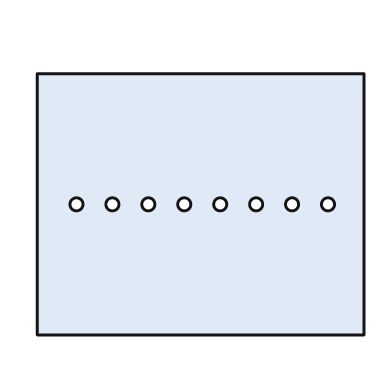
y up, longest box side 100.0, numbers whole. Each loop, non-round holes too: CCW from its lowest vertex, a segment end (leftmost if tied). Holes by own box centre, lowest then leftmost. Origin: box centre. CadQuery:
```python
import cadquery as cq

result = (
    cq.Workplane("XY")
    .moveTo(-50.0, -40.0)
    .lineTo(50.0, -40.0)
    .lineTo(50.0, 40.0)
    .lineTo(-50.0, 40.0)
    .close()
    .moveTo(-38.0, 0.0)
    .circle(2.0)
    .moveTo(-27.0, 0.0)
    .circle(2.0)
    .moveTo(-16.0, 0.0)
    .circle(2.0)
    .moveTo(-5.0, 0.0)
    .circle(2.0)
    .moveTo(6.0, 0.0)
    .circle(2.0)
    .moveTo(17.0, 0.0)
    .circle(2.0)
    .moveTo(28.0, 0.0)
    .circle(2.0)
    .moveTo(39.0, 0.0)
    .circle(2.0)
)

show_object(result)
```